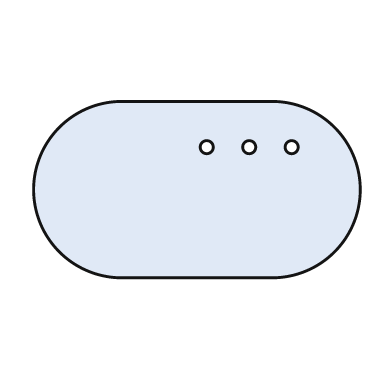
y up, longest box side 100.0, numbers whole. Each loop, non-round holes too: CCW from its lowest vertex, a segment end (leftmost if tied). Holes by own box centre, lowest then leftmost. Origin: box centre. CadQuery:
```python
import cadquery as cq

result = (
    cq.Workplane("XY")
    .moveTo(-23.0, -27.0)
    .lineTo(23.0, -27.0)
    .threePointArc((50.0, 0.0), (23.0, 27.0))
    .lineTo(-23.0, 27.0)
    .threePointArc((-50.0, 0.0), (-23.0, -27.0))
    .close()
    .moveTo(3.0, 13.0)
    .circle(2.0)
    .moveTo(16.0, 13.0)
    .circle(2.0)
    .moveTo(29.0, 13.0)
    .circle(2.0)
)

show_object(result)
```